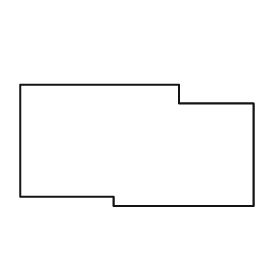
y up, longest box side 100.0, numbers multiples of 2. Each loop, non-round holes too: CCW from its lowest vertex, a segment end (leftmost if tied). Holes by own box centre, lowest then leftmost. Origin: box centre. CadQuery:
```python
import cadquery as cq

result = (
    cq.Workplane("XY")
    .moveTo(-10.0, -26.0)
    .lineTo(50.0, -26.0)
    .lineTo(50.0, 18.0)
    .lineTo(18.0, 18.0)
    .lineTo(18.0, 26.0)
    .lineTo(-50.0, 26.0)
    .lineTo(-50.0, -22.0)
    .lineTo(-10.0, -22.0)
    .close()
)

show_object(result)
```